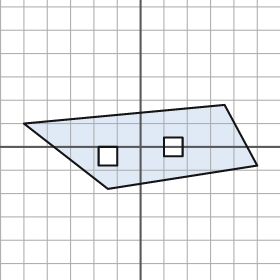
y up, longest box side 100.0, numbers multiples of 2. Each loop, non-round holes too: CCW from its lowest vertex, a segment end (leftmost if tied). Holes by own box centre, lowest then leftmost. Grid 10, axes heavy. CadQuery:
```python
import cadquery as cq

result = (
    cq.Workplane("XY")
    .moveTo(-14.0, -18.0)
    .lineTo(50.0, -8.0)
    .lineTo(36.0, 18.0)
    .lineTo(-50.0, 10.0)
    .close()
    .moveTo(-18.0, -8.0)
    .lineTo(-10.0, -8.0)
    .lineTo(-10.0, 0.0)
    .lineTo(-18.0, 0.0)
    .close()
    .moveTo(10.0, -4.0)
    .lineTo(18.0, -4.0)
    .lineTo(18.0, 4.0)
    .lineTo(10.0, 4.0)
    .close()
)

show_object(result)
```